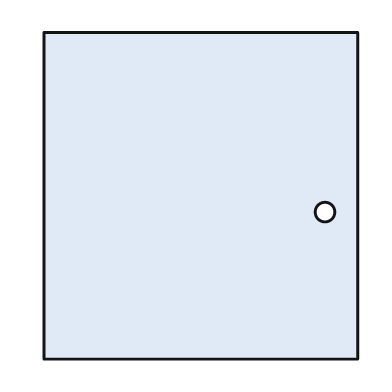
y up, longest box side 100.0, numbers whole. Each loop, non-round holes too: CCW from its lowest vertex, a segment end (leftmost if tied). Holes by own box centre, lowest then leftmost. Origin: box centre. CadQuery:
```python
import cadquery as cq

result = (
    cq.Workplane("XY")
    .moveTo(-48.0, -50.0)
    .lineTo(48.0, -50.0)
    .lineTo(48.0, 50.0)
    .lineTo(-48.0, 50.0)
    .close()
    .moveTo(38.0, -5.0)
    .circle(3.0)
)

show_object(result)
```